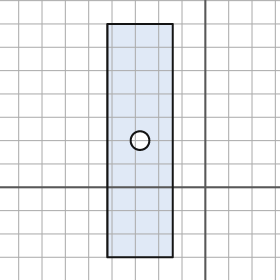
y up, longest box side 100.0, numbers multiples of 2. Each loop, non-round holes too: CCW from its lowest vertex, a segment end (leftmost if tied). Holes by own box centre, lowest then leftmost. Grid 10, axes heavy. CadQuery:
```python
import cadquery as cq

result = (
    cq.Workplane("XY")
    .moveTo(-42.0, -30.0)
    .lineTo(-14.0, -30.0)
    .lineTo(-14.0, 70.0)
    .lineTo(-42.0, 70.0)
    .close()
    .moveTo(-28.0, 20.0)
    .circle(4.0)
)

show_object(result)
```